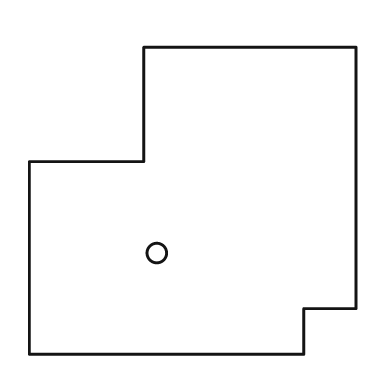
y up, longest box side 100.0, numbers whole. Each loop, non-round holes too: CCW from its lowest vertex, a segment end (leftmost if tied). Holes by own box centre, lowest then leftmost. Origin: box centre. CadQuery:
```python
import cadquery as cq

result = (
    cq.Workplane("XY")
    .moveTo(-50.0, -47.0)
    .lineTo(34.0, -47.0)
    .lineTo(34.0, -33.0)
    .lineTo(50.0, -33.0)
    .lineTo(50.0, 47.0)
    .lineTo(-15.0, 47.0)
    .lineTo(-15.0, 12.0)
    .lineTo(-50.0, 12.0)
    .close()
    .moveTo(-11.0, -16.0)
    .circle(3.0)
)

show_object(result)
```